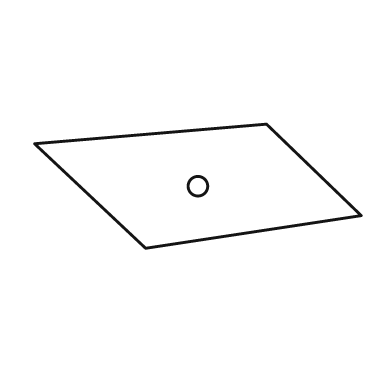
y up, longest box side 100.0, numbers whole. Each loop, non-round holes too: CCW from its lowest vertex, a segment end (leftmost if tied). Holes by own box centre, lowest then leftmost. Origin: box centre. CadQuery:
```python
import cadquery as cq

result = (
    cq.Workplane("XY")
    .moveTo(-16.0, -19.0)
    .lineTo(50.0, -9.0)
    .lineTo(21.0, 19.0)
    .lineTo(-50.0, 13.0)
    .close()
    .moveTo(0.0, 0.0)
    .circle(3.0)
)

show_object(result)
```